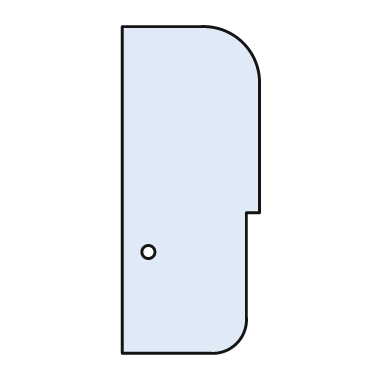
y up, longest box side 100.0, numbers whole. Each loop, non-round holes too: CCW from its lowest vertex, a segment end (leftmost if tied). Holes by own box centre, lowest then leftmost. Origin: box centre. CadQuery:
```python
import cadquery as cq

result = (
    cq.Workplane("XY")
    .moveTo(-21.0, -50.0)
    .lineTo(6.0, -50.0)
    .threePointArc((14.0, -47.0), (17.0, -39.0))
    .lineTo(17.0, -7.0)
    .lineTo(21.0, -7.0)
    .lineTo(21.0, 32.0)
    .threePointArc((16.0, 45.0), (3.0, 50.0))
    .lineTo(-21.0, 50.0)
    .close()
    .moveTo(-13.0, -19.0)
    .circle(2.0)
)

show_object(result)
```